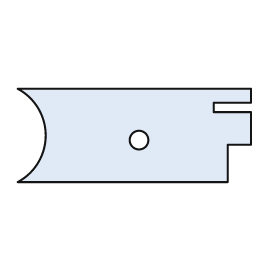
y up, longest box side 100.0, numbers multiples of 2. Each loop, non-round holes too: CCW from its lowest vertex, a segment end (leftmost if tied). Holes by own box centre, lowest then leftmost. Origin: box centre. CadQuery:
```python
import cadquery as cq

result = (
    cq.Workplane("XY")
    .moveTo(-50.0, -20.0)
    .lineTo(40.0, -20.0)
    .lineTo(40.0, -4.0)
    .lineTo(50.0, -4.0)
    .lineTo(50.0, 10.0)
    .lineTo(34.0, 10.0)
    .lineTo(34.0, 14.0)
    .lineTo(50.0, 14.0)
    .lineTo(50.0, 20.0)
    .lineTo(-50.0, 20.0)
    .threePointArc((-38.0, 0.0), (-50.0, -20.0))
    .close()
    .moveTo(2.0, -2.0)
    .circle(4.0)
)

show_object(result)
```